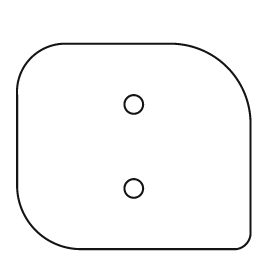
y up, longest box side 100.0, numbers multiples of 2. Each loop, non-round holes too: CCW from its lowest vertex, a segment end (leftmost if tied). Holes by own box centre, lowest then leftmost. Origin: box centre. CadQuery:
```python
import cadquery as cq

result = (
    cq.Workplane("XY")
    .moveTo(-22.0, -44.0)
    .lineTo(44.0, -44.0)
    .threePointArc((48.0, -42.0), (50.0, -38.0))
    .lineTo(50.0, 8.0)
    .threePointArc((40.0, 34.0), (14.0, 44.0))
    .lineTo(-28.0, 44.0)
    .threePointArc((-44.0, 38.0), (-50.0, 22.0))
    .lineTo(-50.0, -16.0)
    .threePointArc((-42.0, -36.0), (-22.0, -44.0))
    .close()
    .moveTo(0.0, -18.0)
    .circle(4.0)
    .moveTo(0.0, 18.0)
    .circle(4.0)
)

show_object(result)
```